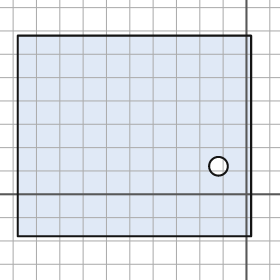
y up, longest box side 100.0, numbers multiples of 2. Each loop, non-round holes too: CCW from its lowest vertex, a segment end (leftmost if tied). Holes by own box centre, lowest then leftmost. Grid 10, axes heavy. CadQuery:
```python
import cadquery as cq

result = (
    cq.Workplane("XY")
    .moveTo(-98.0, -18.0)
    .lineTo(2.0, -18.0)
    .lineTo(2.0, 68.0)
    .lineTo(-98.0, 68.0)
    .close()
    .moveTo(-12.0, 12.0)
    .circle(4.0)
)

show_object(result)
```